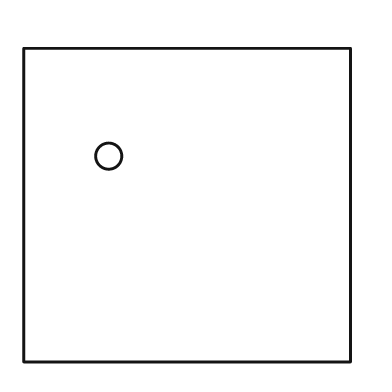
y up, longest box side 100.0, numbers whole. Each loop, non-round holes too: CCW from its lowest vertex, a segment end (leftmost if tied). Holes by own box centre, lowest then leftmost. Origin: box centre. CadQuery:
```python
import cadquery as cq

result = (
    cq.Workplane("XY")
    .moveTo(-50.0, -48.0)
    .lineTo(50.0, -48.0)
    .lineTo(50.0, 48.0)
    .lineTo(-50.0, 48.0)
    .close()
    .moveTo(-24.0, 15.0)
    .circle(4.0)
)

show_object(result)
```